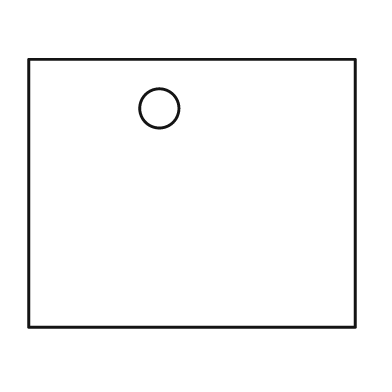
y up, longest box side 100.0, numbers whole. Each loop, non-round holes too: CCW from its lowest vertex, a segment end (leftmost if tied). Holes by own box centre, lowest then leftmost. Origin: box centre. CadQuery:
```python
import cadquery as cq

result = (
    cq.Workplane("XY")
    .moveTo(-50.0, -41.0)
    .lineTo(50.0, -41.0)
    .lineTo(50.0, 41.0)
    .lineTo(-50.0, 41.0)
    .close()
    .moveTo(-10.0, 26.0)
    .circle(6.0)
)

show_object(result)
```